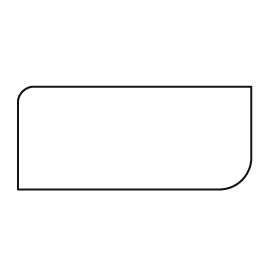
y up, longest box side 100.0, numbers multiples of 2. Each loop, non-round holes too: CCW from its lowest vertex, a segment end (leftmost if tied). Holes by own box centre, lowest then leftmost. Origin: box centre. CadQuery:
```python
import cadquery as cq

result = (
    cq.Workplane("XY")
    .moveTo(-50.0, -22.0)
    .lineTo(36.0, -22.0)
    .threePointArc((46.0, -18.0), (50.0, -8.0))
    .lineTo(50.0, 22.0)
    .lineTo(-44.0, 22.0)
    .threePointArc((-48.0, 20.0), (-50.0, 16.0))
    .close()
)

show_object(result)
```